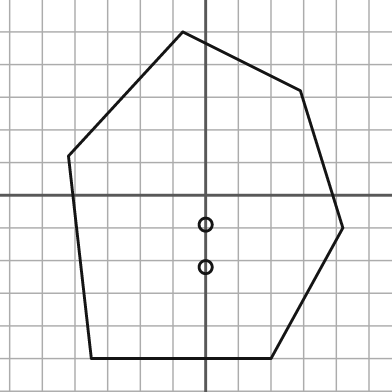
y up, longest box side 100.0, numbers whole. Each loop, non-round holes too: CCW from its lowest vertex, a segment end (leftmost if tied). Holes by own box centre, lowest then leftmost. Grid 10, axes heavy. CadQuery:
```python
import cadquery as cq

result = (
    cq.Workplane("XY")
    .moveTo(-35.0, -50.0)
    .lineTo(20.0, -50.0)
    .lineTo(42.0, -10.0)
    .lineTo(29.0, 32.0)
    .lineTo(-7.0, 50.0)
    .lineTo(-42.0, 12.0)
    .close()
    .moveTo(0.0, -22.0)
    .circle(2.0)
    .moveTo(0.0, -9.0)
    .circle(2.0)
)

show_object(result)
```